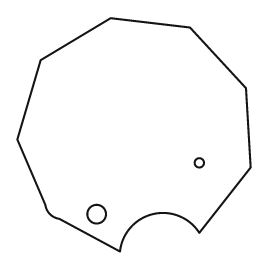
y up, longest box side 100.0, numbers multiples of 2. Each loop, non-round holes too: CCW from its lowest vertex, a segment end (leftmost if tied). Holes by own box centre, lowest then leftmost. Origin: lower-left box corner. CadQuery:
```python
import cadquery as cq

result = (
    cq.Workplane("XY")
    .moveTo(44.0, 0.0)
    .threePointArc((58.0, 16.0), (78.0, 8.0))
    .lineTo(100.0, 36.0)
    .lineTo(98.0, 70.0)
    .lineTo(74.0, 96.0)
    .lineTo(40.0, 100.0)
    .lineTo(10.0, 82.0)
    .lineTo(0.0, 48.0)
    .lineTo(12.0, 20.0)
    .threePointArc((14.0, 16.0), (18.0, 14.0))
    .close()
    .moveTo(34.0, 16.0)
    .circle(4.0)
    .moveTo(78.0, 38.0)
    .circle(2.0)
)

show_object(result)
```